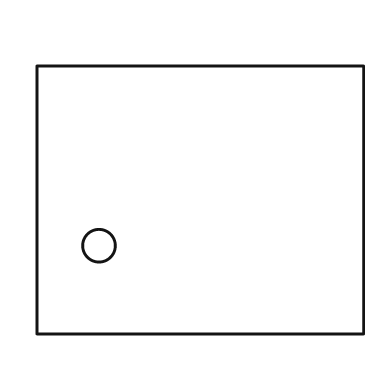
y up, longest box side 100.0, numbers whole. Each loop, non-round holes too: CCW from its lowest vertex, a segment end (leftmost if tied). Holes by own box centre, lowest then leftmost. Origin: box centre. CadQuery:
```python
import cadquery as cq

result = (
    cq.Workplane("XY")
    .moveTo(-50.0, -41.0)
    .lineTo(50.0, -41.0)
    .lineTo(50.0, 41.0)
    .lineTo(-50.0, 41.0)
    .close()
    .moveTo(-31.0, -14.0)
    .circle(5.0)
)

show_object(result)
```